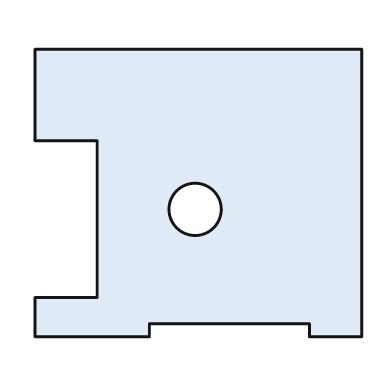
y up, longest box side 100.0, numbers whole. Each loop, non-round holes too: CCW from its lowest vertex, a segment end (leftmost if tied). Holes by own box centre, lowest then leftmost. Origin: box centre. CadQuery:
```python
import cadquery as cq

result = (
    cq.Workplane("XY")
    .moveTo(-50.0, -44.0)
    .lineTo(-15.0, -44.0)
    .lineTo(-15.0, -40.0)
    .lineTo(34.0, -40.0)
    .lineTo(34.0, -44.0)
    .lineTo(50.0, -44.0)
    .lineTo(50.0, 44.0)
    .lineTo(-50.0, 44.0)
    .lineTo(-50.0, 16.0)
    .lineTo(-31.0, 16.0)
    .lineTo(-31.0, -32.0)
    .lineTo(-50.0, -32.0)
    .close()
    .moveTo(-1.0, -5.0)
    .circle(8.0)
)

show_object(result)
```